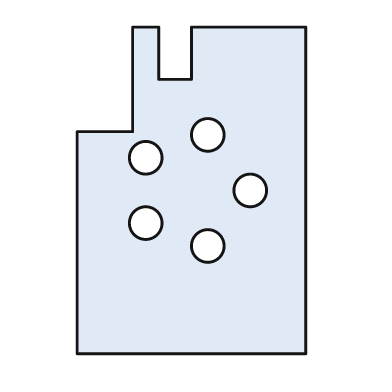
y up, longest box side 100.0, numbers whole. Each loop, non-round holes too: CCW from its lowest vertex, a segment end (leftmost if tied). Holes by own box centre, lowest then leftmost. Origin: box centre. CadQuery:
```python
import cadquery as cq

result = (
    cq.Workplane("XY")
    .moveTo(-35.0, -50.0)
    .lineTo(35.0, -50.0)
    .lineTo(35.0, 50.0)
    .lineTo(0.0, 50.0)
    .lineTo(0.0, 34.0)
    .lineTo(-10.0, 34.0)
    .lineTo(-10.0, 50.0)
    .lineTo(-18.0, 50.0)
    .lineTo(-18.0, 18.0)
    .lineTo(-35.0, 18.0)
    .close()
    .moveTo(5.0, -17.0)
    .circle(5.0)
    .moveTo(-14.0, -10.0)
    .circle(5.0)
    .moveTo(18.0, 0.0)
    .circle(5.0)
    .moveTo(-14.0, 10.0)
    .circle(5.0)
    .moveTo(5.0, 17.0)
    .circle(5.0)
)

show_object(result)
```